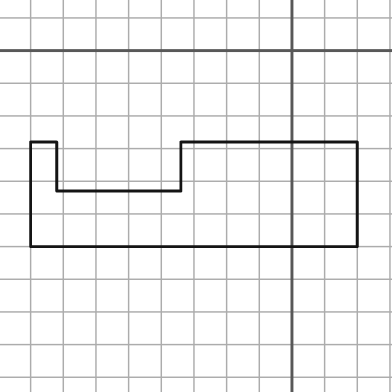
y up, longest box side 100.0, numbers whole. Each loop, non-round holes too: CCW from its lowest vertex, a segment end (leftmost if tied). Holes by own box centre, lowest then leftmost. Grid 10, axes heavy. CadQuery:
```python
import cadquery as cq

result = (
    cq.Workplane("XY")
    .moveTo(-80.0, -60.0)
    .lineTo(20.0, -60.0)
    .lineTo(20.0, -28.0)
    .lineTo(-34.0, -28.0)
    .lineTo(-34.0, -43.0)
    .lineTo(-72.0, -43.0)
    .lineTo(-72.0, -28.0)
    .lineTo(-80.0, -28.0)
    .close()
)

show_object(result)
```